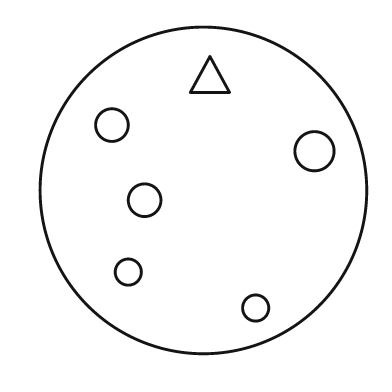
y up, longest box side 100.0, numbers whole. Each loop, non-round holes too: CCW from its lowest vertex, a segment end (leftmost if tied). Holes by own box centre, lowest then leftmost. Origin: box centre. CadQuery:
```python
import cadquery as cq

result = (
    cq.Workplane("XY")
    .moveTo(0.0, 0.0)
    .circle(50.0)
    .moveTo(16.0, -36.0)
    .circle(4.0)
    .moveTo(-23.0, -25.0)
    .circle(4.0)
    .moveTo(-18.0, -3.0)
    .circle(5.0)
    .moveTo(34.0, 12.0)
    .circle(6.0)
    .moveTo(-28.0, 20.0)
    .circle(5.0)
    .moveTo(-4.0, 30.0)
    .lineTo(8.0, 30.0)
    .lineTo(2.0, 41.0)
    .close()
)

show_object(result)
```